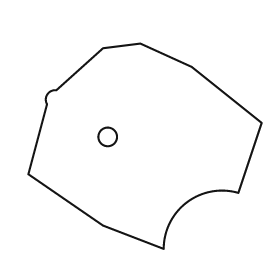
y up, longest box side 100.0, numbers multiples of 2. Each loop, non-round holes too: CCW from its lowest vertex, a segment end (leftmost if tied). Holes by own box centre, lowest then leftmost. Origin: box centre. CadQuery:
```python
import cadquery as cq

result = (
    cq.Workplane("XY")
    .moveTo(8.0, -44.0)
    .threePointArc((18.0, -24.0), (40.0, -20.0))
    .lineTo(50.0, 10.0)
    .lineTo(20.0, 34.0)
    .lineTo(-2.0, 44.0)
    .lineTo(-18.0, 42.0)
    .lineTo(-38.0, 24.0)
    .threePointArc((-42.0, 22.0), (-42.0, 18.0))
    .lineTo(-50.0, -12.0)
    .lineTo(-18.0, -34.0)
    .close()
    .moveTo(-16.0, 4.0)
    .circle(4.0)
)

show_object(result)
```